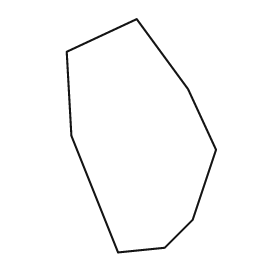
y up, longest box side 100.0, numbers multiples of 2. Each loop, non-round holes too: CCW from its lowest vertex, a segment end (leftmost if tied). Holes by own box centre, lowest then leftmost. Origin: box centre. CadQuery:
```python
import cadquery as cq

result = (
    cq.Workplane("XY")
    .moveTo(-10.0, -50.0)
    .lineTo(10.0, -48.0)
    .lineTo(22.0, -36.0)
    .lineTo(32.0, -6.0)
    .lineTo(20.0, 20.0)
    .lineTo(-2.0, 50.0)
    .lineTo(-32.0, 36.0)
    .lineTo(-30.0, 0.0)
    .close()
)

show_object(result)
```